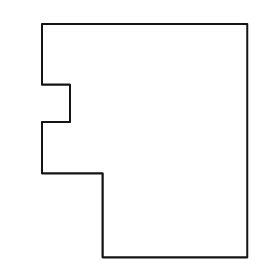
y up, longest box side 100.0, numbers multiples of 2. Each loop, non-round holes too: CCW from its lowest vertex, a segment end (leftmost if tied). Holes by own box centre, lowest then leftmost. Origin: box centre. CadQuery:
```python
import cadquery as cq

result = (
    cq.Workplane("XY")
    .moveTo(-18.0, -50.0)
    .lineTo(44.0, -50.0)
    .lineTo(44.0, 50.0)
    .lineTo(-44.0, 50.0)
    .lineTo(-44.0, 24.0)
    .lineTo(-32.0, 24.0)
    .lineTo(-32.0, 8.0)
    .lineTo(-44.0, 8.0)
    .lineTo(-44.0, -14.0)
    .lineTo(-18.0, -14.0)
    .close()
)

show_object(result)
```